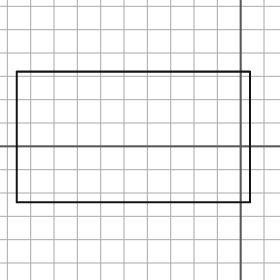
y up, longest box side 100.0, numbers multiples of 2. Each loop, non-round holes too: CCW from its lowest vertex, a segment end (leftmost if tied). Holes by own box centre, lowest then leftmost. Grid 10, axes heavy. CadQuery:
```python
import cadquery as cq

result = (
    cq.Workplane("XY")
    .moveTo(-96.0, -24.0)
    .lineTo(4.0, -24.0)
    .lineTo(4.0, 32.0)
    .lineTo(-96.0, 32.0)
    .close()
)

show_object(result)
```